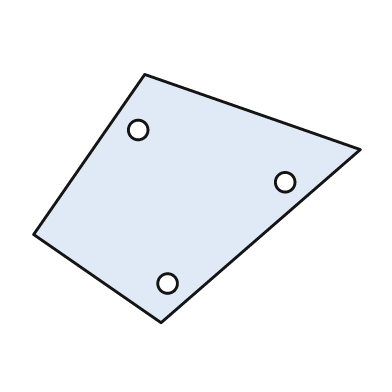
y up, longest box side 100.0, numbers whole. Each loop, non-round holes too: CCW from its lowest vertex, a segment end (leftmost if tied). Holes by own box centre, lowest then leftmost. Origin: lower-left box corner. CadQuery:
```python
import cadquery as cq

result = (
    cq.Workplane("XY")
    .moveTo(39.0, 0.0)
    .lineTo(100.0, 53.0)
    .lineTo(34.0, 76.0)
    .lineTo(0.0, 27.0)
    .close()
    .moveTo(41.0, 12.0)
    .circle(3.0)
    .moveTo(77.0, 43.0)
    .circle(3.0)
    .moveTo(32.0, 59.0)
    .circle(3.0)
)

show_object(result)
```